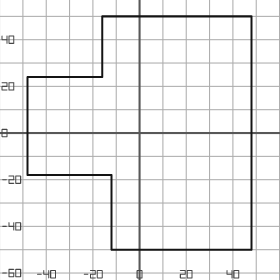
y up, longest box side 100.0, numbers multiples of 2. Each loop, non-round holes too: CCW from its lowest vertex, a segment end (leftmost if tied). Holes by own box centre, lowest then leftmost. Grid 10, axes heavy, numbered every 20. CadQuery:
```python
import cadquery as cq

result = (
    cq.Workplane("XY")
    .moveTo(-12.0, -50.0)
    .lineTo(48.0, -50.0)
    .lineTo(48.0, 50.0)
    .lineTo(-16.0, 50.0)
    .lineTo(-16.0, 24.0)
    .lineTo(-48.0, 24.0)
    .lineTo(-48.0, -18.0)
    .lineTo(-12.0, -18.0)
    .close()
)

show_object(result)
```